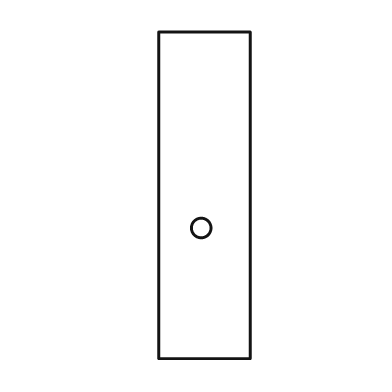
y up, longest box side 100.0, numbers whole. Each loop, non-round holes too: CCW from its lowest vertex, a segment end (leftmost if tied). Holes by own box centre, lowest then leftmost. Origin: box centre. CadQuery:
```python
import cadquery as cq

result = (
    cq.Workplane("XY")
    .moveTo(-14.0, -50.0)
    .lineTo(14.0, -50.0)
    .lineTo(14.0, 50.0)
    .lineTo(-14.0, 50.0)
    .close()
    .moveTo(-1.0, -10.0)
    .circle(3.0)
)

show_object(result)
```